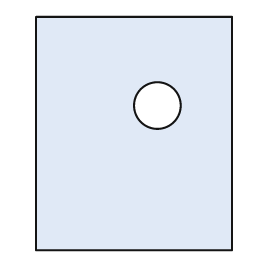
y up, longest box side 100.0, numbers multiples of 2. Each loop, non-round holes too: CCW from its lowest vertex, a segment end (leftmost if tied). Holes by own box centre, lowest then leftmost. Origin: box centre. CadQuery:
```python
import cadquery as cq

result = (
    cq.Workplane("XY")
    .moveTo(-42.0, -50.0)
    .lineTo(42.0, -50.0)
    .lineTo(42.0, 50.0)
    .lineTo(-42.0, 50.0)
    .close()
    .moveTo(10.0, 12.0)
    .circle(10.0)
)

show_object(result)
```